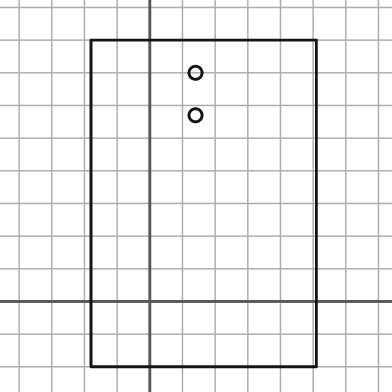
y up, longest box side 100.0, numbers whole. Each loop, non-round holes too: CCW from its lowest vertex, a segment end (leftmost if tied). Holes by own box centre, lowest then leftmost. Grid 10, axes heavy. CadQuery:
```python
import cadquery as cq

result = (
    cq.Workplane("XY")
    .moveTo(-18.0, -20.0)
    .lineTo(51.0, -20.0)
    .lineTo(51.0, 80.0)
    .lineTo(-18.0, 80.0)
    .close()
    .moveTo(14.0, 57.0)
    .circle(2.0)
    .moveTo(14.0, 70.0)
    .circle(2.0)
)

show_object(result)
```